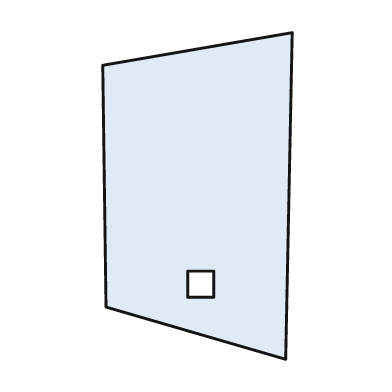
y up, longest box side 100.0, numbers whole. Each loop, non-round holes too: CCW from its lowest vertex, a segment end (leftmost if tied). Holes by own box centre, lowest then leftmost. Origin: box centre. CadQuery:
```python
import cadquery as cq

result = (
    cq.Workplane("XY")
    .moveTo(27.0, -50.0)
    .lineTo(29.0, 50.0)
    .lineTo(-29.0, 40.0)
    .lineTo(-28.0, -34.0)
    .close()
    .moveTo(-3.0, -31.0)
    .lineTo(5.0, -31.0)
    .lineTo(5.0, -23.0)
    .lineTo(-3.0, -23.0)
    .close()
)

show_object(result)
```